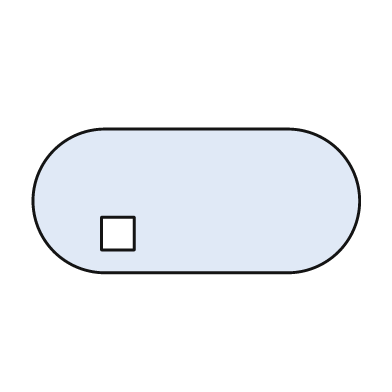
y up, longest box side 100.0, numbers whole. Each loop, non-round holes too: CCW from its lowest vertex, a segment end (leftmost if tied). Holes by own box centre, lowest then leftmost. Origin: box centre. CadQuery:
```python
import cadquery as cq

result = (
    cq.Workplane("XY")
    .moveTo(-28.0, -22.0)
    .lineTo(28.0, -22.0)
    .threePointArc((50.0, 0.0), (28.0, 22.0))
    .lineTo(-28.0, 22.0)
    .threePointArc((-50.0, 0.0), (-28.0, -22.0))
    .close()
    .moveTo(-29.0, -15.0)
    .lineTo(-19.0, -15.0)
    .lineTo(-19.0, -5.0)
    .lineTo(-29.0, -5.0)
    .close()
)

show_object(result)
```